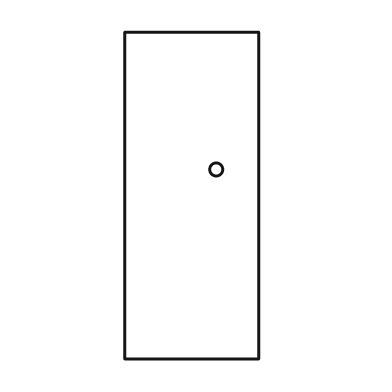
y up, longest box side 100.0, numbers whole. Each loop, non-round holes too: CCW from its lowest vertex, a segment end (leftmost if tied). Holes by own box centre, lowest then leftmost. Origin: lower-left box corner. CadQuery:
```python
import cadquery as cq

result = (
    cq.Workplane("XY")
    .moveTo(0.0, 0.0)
    .lineTo(41.0, 0.0)
    .lineTo(41.0, 100.0)
    .lineTo(0.0, 100.0)
    .close()
    .moveTo(28.0, 58.0)
    .circle(2.0)
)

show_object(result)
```